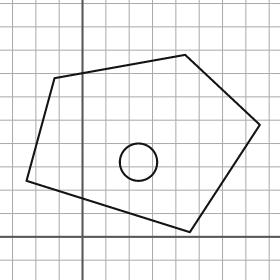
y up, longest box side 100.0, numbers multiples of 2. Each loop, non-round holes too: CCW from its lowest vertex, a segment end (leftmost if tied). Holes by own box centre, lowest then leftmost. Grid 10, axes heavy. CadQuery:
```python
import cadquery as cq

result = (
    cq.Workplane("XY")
    .moveTo(46.0, 2.0)
    .lineTo(76.0, 48.0)
    .lineTo(44.0, 78.0)
    .lineTo(-12.0, 68.0)
    .lineTo(-24.0, 24.0)
    .close()
    .moveTo(24.0, 32.0)
    .circle(8.0)
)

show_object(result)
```